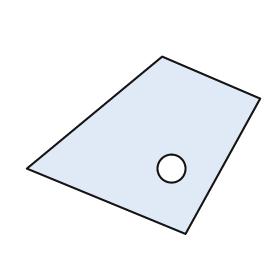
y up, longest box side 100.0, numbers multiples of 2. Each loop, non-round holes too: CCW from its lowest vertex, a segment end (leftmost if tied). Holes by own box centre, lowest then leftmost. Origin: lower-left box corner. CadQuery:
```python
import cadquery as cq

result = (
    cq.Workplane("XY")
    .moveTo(68.0, 0.0)
    .lineTo(100.0, 58.0)
    .lineTo(58.0, 76.0)
    .lineTo(0.0, 28.0)
    .close()
    .moveTo(62.0, 28.0)
    .circle(6.0)
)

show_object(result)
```